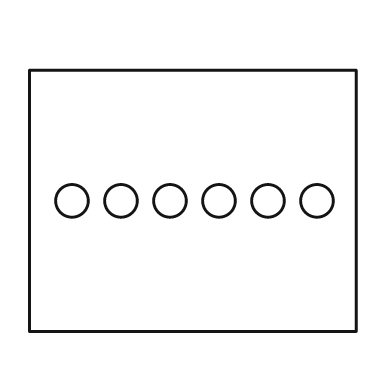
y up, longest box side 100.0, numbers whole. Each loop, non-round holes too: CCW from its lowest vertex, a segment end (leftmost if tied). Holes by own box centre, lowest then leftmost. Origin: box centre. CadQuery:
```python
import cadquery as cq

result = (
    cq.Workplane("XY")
    .moveTo(-50.0, -40.0)
    .lineTo(50.0, -40.0)
    .lineTo(50.0, 40.0)
    .lineTo(-50.0, 40.0)
    .close()
    .moveTo(-37.0, 0.0)
    .circle(5.0)
    .moveTo(-22.0, 0.0)
    .circle(5.0)
    .moveTo(-7.0, 0.0)
    .circle(5.0)
    .moveTo(8.0, 0.0)
    .circle(5.0)
    .moveTo(23.0, 0.0)
    .circle(5.0)
    .moveTo(38.0, 0.0)
    .circle(5.0)
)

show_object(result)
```